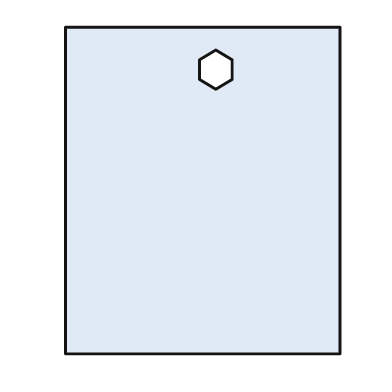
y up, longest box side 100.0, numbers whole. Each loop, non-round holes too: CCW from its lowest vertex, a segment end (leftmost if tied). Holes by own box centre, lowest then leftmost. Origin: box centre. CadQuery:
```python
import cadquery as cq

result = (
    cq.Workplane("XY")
    .moveTo(-42.0, -50.0)
    .lineTo(42.0, -50.0)
    .lineTo(42.0, 50.0)
    .lineTo(-42.0, 50.0)
    .close()
    .moveTo(4.0, 31.0)
    .lineTo(9.0, 34.0)
    .lineTo(9.0, 40.0)
    .lineTo(4.0, 43.0)
    .lineTo(-1.0, 40.0)
    .lineTo(-1.0, 34.0)
    .close()
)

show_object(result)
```